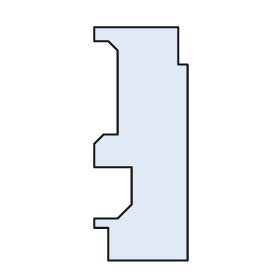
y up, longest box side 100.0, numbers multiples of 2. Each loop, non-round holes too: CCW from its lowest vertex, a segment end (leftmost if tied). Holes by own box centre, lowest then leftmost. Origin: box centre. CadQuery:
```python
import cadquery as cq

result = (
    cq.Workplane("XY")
    .moveTo(-14.0, -50.0)
    .lineTo(20.0, -50.0)
    .lineTo(20.0, 34.0)
    .lineTo(16.0, 34.0)
    .lineTo(16.0, 50.0)
    .lineTo(-20.0, 50.0)
    .lineTo(-20.0, 44.0)
    .lineTo(-14.0, 44.0)
    .lineTo(-10.0, 40.0)
    .lineTo(-10.0, 4.0)
    .lineTo(-16.0, 4.0)
    .lineTo(-20.0, 0.0)
    .lineTo(-20.0, -10.0)
    .lineTo(-4.0, -10.0)
    .lineTo(-4.0, -26.0)
    .lineTo(-10.0, -32.0)
    .lineTo(-20.0, -32.0)
    .lineTo(-20.0, -36.0)
    .lineTo(-14.0, -36.0)
    .close()
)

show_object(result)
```